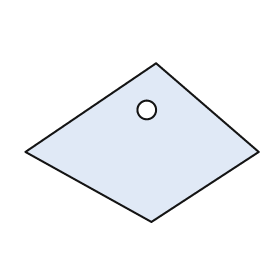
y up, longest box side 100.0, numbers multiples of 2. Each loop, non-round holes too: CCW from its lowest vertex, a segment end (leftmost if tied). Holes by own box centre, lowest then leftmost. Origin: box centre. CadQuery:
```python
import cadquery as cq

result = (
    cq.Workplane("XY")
    .moveTo(4.0, -34.0)
    .lineTo(50.0, -4.0)
    .lineTo(6.0, 34.0)
    .lineTo(-50.0, -4.0)
    .close()
    .moveTo(2.0, 14.0)
    .circle(4.0)
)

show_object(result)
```